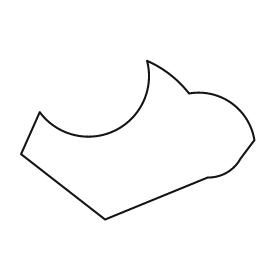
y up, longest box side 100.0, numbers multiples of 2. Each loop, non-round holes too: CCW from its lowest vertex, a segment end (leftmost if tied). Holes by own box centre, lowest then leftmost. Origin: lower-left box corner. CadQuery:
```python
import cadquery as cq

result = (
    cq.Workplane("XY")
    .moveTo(36.0, 0.0)
    .lineTo(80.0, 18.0)
    .threePointArc((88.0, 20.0), (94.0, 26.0))
    .lineTo(100.0, 34.0)
    .threePointArc((90.0, 50.0), (72.0, 54.0))
    .threePointArc((64.0, 62.0), (54.0, 68.0))
    .threePointArc((40.0, 38.0), (8.0, 46.0))
    .lineTo(0.0, 28.0)
    .close()
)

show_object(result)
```